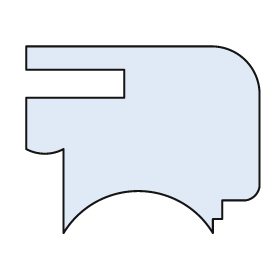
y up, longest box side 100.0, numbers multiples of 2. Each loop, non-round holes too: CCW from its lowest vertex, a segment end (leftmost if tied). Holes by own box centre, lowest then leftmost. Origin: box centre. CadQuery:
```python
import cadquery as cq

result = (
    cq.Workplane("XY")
    .moveTo(-34.0, -40.0)
    .threePointArc((-2.0, -22.0), (30.0, -40.0))
    .lineTo(30.0, -34.0)
    .lineTo(34.0, -34.0)
    .lineTo(34.0, -26.0)
    .lineTo(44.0, -26.0)
    .threePointArc((48.0, -24.0), (50.0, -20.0))
    .lineTo(50.0, 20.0)
    .threePointArc((44.0, 34.0), (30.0, 40.0))
    .lineTo(-50.0, 40.0)
    .lineTo(-50.0, 30.0)
    .lineTo(-8.0, 30.0)
    .lineTo(-8.0, 18.0)
    .lineTo(-50.0, 18.0)
    .lineTo(-50.0, -4.0)
    .threePointArc((-42.0, -6.0), (-34.0, -4.0))
    .close()
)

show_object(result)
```